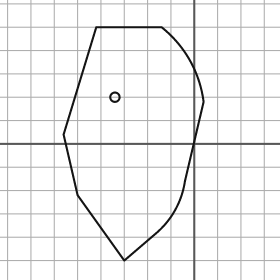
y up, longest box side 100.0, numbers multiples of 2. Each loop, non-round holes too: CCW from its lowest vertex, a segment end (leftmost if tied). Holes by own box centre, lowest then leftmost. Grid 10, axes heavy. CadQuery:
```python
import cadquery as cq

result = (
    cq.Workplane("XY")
    .moveTo(-30.0, -50.0)
    .lineTo(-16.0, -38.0)
    .threePointArc((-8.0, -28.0), (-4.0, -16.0))
    .lineTo(4.0, 18.0)
    .threePointArc((-2.0, 36.0), (-14.0, 50.0))
    .lineTo(-42.0, 50.0)
    .lineTo(-56.0, 4.0)
    .lineTo(-50.0, -22.0)
    .close()
    .moveTo(-34.0, 20.0)
    .circle(2.0)
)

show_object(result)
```